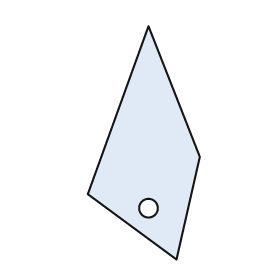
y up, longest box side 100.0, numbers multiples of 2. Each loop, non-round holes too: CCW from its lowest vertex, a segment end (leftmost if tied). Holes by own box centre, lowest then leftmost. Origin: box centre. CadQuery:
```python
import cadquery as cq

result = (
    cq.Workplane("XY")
    .moveTo(14.0, -50.0)
    .lineTo(24.0, -6.0)
    .lineTo(2.0, 50.0)
    .lineTo(-24.0, -22.0)
    .close()
    .moveTo(2.0, -28.0)
    .circle(4.0)
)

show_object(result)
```